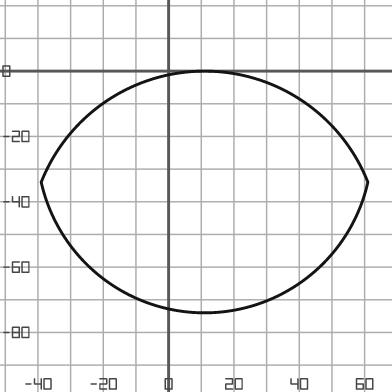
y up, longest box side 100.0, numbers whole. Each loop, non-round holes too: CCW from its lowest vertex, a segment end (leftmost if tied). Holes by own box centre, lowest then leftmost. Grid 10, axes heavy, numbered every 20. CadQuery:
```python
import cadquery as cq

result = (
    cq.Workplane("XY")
    .moveTo(-39.0, -34.0)
    .threePointArc((11.0, -74.0), (61.0, -34.0))
    .threePointArc((11.0, 0.0), (-39.0, -34.0))
    .close()
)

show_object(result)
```